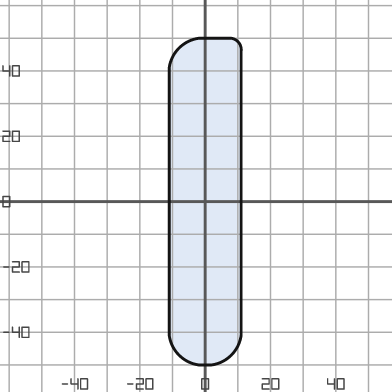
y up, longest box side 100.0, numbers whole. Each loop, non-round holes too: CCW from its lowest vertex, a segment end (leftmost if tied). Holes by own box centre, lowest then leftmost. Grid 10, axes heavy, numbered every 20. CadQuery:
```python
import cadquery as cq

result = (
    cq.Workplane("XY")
    .moveTo(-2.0, -50.0)
    .lineTo(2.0, -50.0)
    .threePointArc((8.0, -47.0), (11.0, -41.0))
    .lineTo(11.0, 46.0)
    .threePointArc((10.0, 49.0), (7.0, 50.0))
    .lineTo(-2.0, 50.0)
    .threePointArc((-8.0, 47.0), (-11.0, 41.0))
    .lineTo(-11.0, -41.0)
    .threePointArc((-8.0, -47.0), (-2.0, -50.0))
    .close()
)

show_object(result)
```